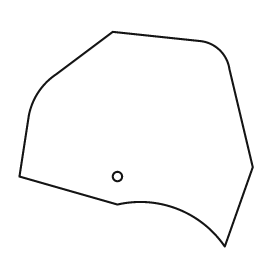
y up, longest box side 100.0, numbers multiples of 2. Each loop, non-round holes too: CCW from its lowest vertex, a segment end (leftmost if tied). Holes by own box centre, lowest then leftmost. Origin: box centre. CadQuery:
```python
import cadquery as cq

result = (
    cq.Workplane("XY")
    .moveTo(38.0, -46.0)
    .lineTo(50.0, -12.0)
    .lineTo(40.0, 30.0)
    .threePointArc((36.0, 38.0), (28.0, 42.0))
    .lineTo(-10.0, 46.0)
    .lineTo(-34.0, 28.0)
    .threePointArc((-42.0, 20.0), (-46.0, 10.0))
    .lineTo(-50.0, -16.0)
    .lineTo(-8.0, -28.0)
    .threePointArc((18.0, -30.0), (38.0, -46.0))
    .close()
    .moveTo(-8.0, -16.0)
    .circle(2.0)
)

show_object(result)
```